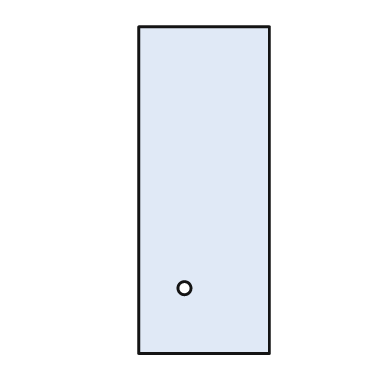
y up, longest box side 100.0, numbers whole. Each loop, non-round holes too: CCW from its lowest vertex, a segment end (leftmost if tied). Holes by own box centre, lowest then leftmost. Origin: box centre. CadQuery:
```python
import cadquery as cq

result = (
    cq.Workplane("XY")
    .moveTo(-20.0, -50.0)
    .lineTo(20.0, -50.0)
    .lineTo(20.0, 50.0)
    .lineTo(-20.0, 50.0)
    .close()
    .moveTo(-6.0, -30.0)
    .circle(2.0)
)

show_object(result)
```